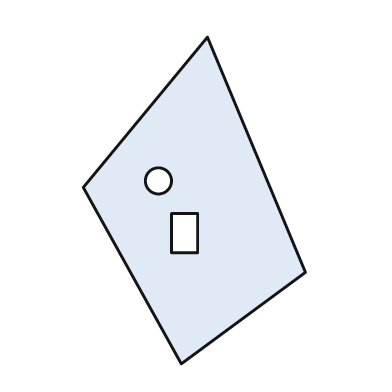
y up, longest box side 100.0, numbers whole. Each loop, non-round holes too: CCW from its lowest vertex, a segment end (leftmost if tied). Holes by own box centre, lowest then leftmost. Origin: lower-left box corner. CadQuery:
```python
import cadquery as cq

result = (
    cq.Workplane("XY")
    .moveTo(30.0, 0.0)
    .lineTo(68.0, 28.0)
    .lineTo(38.0, 100.0)
    .lineTo(0.0, 54.0)
    .close()
    .moveTo(27.0, 34.0)
    .lineTo(35.0, 34.0)
    .lineTo(35.0, 46.0)
    .lineTo(27.0, 46.0)
    .close()
    .moveTo(23.0, 56.0)
    .circle(4.0)
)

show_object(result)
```